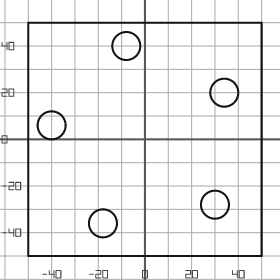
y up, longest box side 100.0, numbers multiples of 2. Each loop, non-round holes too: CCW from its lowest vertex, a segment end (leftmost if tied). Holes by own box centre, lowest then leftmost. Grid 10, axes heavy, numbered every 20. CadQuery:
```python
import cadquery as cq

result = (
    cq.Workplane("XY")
    .moveTo(-50.0, -50.0)
    .lineTo(50.0, -50.0)
    .lineTo(50.0, 50.0)
    .lineTo(-50.0, 50.0)
    .close()
    .moveTo(-18.0, -36.0)
    .circle(6.0)
    .moveTo(30.0, -28.0)
    .circle(6.0)
    .moveTo(-40.0, 6.0)
    .circle(6.0)
    .moveTo(34.0, 20.0)
    .circle(6.0)
    .moveTo(-8.0, 40.0)
    .circle(6.0)
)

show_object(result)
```